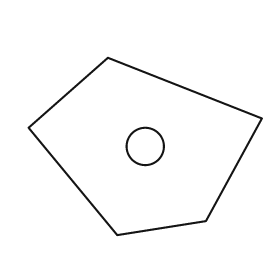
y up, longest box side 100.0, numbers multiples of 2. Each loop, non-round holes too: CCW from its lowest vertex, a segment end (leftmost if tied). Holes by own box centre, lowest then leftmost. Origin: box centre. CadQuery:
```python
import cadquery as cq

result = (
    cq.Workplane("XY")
    .moveTo(-12.0, -38.0)
    .lineTo(26.0, -32.0)
    .lineTo(50.0, 12.0)
    .lineTo(-16.0, 38.0)
    .lineTo(-50.0, 8.0)
    .close()
    .moveTo(0.0, 0.0)
    .circle(8.0)
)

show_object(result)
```